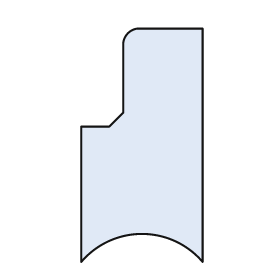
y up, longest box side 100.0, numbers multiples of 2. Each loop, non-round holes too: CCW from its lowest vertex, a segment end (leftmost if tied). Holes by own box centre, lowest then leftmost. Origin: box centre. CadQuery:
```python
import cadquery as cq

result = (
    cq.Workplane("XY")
    .moveTo(-26.0, -50.0)
    .threePointArc((0.0, -38.0), (26.0, -50.0))
    .lineTo(26.0, 50.0)
    .lineTo(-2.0, 50.0)
    .threePointArc((-6.0, 48.0), (-8.0, 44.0))
    .lineTo(-8.0, 14.0)
    .lineTo(-14.0, 8.0)
    .lineTo(-26.0, 8.0)
    .close()
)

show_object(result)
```